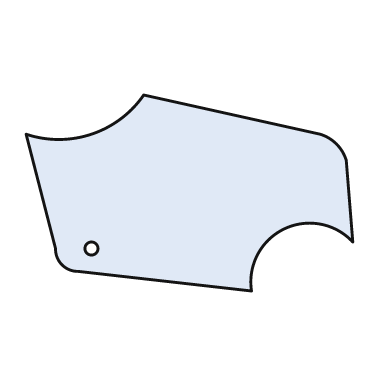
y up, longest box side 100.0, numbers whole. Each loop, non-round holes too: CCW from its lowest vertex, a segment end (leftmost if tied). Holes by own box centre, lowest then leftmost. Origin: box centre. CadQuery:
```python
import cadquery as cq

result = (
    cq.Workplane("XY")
    .moveTo(19.0, -30.0)
    .threePointArc((29.0, -11.0), (50.0, -15.0))
    .lineTo(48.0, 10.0)
    .threePointArc((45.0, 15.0), (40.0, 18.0))
    .lineTo(-14.0, 30.0)
    .threePointArc((-30.0, 18.0), (-50.0, 18.0))
    .lineTo(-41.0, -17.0)
    .threePointArc((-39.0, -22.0), (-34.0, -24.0))
    .close()
    .moveTo(-30.0, -17.0)
    .circle(2.0)
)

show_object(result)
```